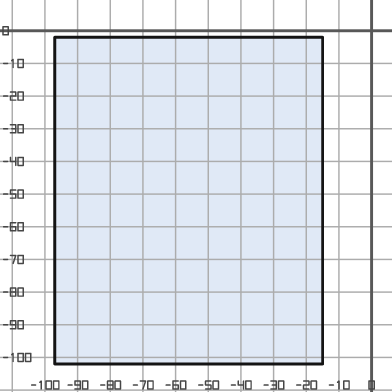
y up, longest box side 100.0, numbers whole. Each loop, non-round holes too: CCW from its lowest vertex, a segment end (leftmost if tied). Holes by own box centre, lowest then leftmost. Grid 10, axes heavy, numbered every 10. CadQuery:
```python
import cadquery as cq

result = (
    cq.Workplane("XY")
    .moveTo(-97.0, -102.0)
    .lineTo(-15.0, -102.0)
    .lineTo(-15.0, -2.0)
    .lineTo(-97.0, -2.0)
    .close()
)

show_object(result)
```